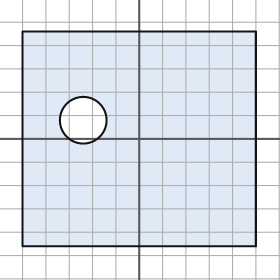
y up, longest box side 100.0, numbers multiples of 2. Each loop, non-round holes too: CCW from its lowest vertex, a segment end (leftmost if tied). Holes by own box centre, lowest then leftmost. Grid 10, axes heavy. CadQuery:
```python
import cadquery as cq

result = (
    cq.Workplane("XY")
    .moveTo(-50.0, -46.0)
    .lineTo(50.0, -46.0)
    .lineTo(50.0, 46.0)
    .lineTo(-50.0, 46.0)
    .close()
    .moveTo(-24.0, 8.0)
    .circle(10.0)
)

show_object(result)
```